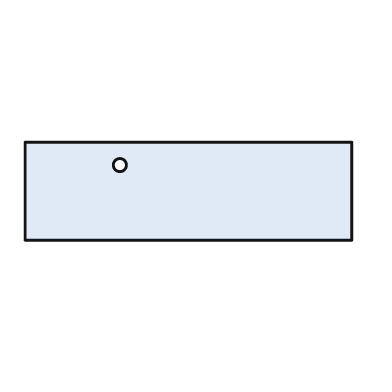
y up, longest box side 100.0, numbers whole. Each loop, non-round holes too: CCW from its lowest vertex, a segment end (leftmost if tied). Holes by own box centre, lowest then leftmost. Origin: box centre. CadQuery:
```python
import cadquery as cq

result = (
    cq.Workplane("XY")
    .moveTo(-50.0, -15.0)
    .lineTo(50.0, -15.0)
    .lineTo(50.0, 15.0)
    .lineTo(-50.0, 15.0)
    .close()
    .moveTo(-21.0, 8.0)
    .circle(2.0)
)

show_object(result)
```